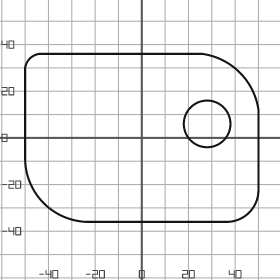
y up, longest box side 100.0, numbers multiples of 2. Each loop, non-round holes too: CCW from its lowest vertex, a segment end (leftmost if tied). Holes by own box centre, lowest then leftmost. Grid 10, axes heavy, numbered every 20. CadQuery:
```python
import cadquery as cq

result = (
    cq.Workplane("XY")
    .moveTo(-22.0, -36.0)
    .lineTo(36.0, -36.0)
    .threePointArc((46.0, -32.0), (50.0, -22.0))
    .lineTo(50.0, 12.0)
    .threePointArc((42.0, 28.0), (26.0, 36.0))
    .lineTo(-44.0, 36.0)
    .threePointArc((-48.0, 34.0), (-50.0, 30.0))
    .lineTo(-50.0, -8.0)
    .threePointArc((-42.0, -28.0), (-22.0, -36.0))
    .close()
    .moveTo(28.0, 6.0)
    .circle(10.0)
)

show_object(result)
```